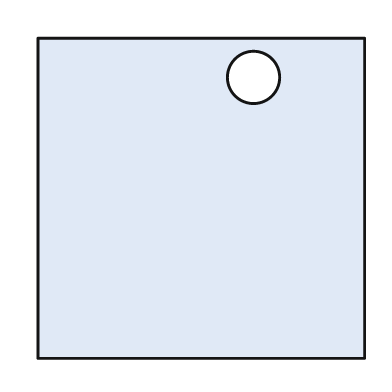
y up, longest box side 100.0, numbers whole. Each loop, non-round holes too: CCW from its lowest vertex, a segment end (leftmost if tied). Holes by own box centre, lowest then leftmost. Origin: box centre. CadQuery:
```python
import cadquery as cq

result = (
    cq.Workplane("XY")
    .moveTo(-50.0, -49.0)
    .lineTo(50.0, -49.0)
    .lineTo(50.0, 49.0)
    .lineTo(-50.0, 49.0)
    .close()
    .moveTo(16.0, 37.0)
    .circle(8.0)
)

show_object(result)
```